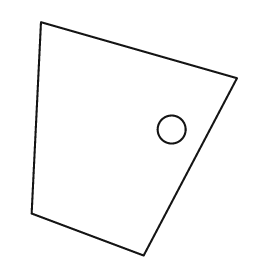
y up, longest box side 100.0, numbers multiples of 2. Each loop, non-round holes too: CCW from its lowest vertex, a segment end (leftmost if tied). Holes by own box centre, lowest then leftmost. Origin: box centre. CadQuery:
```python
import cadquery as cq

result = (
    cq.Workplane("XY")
    .moveTo(4.0, -50.0)
    .lineTo(44.0, 26.0)
    .lineTo(-40.0, 50.0)
    .lineTo(-44.0, -32.0)
    .close()
    .moveTo(16.0, 4.0)
    .circle(6.0)
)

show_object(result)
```